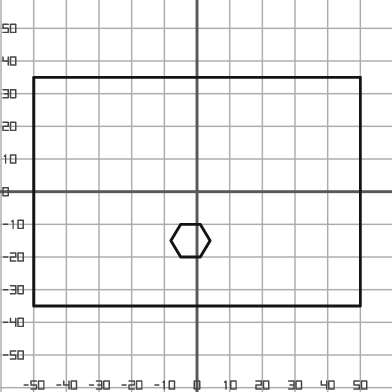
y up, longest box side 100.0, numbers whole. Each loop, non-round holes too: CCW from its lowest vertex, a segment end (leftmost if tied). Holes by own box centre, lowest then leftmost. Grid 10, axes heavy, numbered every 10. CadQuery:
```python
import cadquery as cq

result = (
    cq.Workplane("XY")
    .moveTo(-50.0, -35.0)
    .lineTo(50.0, -35.0)
    .lineTo(50.0, 35.0)
    .lineTo(-50.0, 35.0)
    .close()
    .moveTo(-5.0, -20.0)
    .lineTo(1.0, -20.0)
    .lineTo(4.0, -15.0)
    .lineTo(1.0, -10.0)
    .lineTo(-5.0, -10.0)
    .lineTo(-8.0, -15.0)
    .close()
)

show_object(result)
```